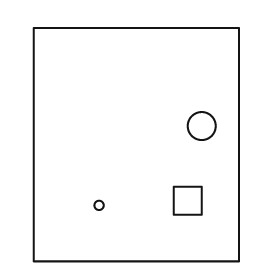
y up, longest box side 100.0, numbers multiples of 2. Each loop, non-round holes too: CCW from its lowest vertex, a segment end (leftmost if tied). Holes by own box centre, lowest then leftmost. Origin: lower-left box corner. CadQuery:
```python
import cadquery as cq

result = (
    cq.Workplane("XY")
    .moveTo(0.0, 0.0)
    .lineTo(88.0, 0.0)
    .lineTo(88.0, 100.0)
    .lineTo(0.0, 100.0)
    .close()
    .moveTo(28.0, 24.0)
    .circle(2.0)
    .moveTo(60.0, 20.0)
    .lineTo(72.0, 20.0)
    .lineTo(72.0, 32.0)
    .lineTo(60.0, 32.0)
    .close()
    .moveTo(72.0, 58.0)
    .circle(6.0)
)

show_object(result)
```